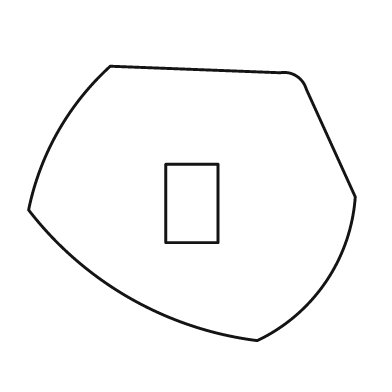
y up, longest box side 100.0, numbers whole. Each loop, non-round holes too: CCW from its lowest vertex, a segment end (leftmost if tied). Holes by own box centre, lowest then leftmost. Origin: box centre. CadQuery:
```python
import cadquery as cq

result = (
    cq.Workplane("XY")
    .moveTo(20.0, -42.0)
    .threePointArc((41.0, -24.0), (50.0, 2.0))
    .lineTo(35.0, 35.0)
    .threePointArc((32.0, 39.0), (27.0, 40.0))
    .lineTo(-25.0, 42.0)
    .threePointArc((-41.0, 22.0), (-50.0, -2.0))
    .threePointArc((-19.0, -29.0), (20.0, -42.0))
    .close()
    .moveTo(-8.0, -12.0)
    .lineTo(8.0, -12.0)
    .lineTo(8.0, 12.0)
    .lineTo(-8.0, 12.0)
    .close()
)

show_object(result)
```